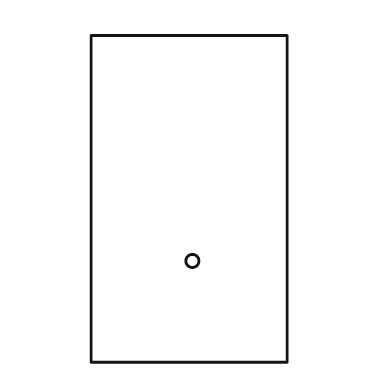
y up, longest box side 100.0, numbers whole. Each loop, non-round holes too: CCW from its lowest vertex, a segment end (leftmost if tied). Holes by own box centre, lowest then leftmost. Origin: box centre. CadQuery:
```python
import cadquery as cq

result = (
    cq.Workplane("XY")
    .moveTo(-30.0, -50.0)
    .lineTo(30.0, -50.0)
    .lineTo(30.0, 50.0)
    .lineTo(-30.0, 50.0)
    .close()
    .moveTo(1.0, -19.0)
    .circle(2.0)
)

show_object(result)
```